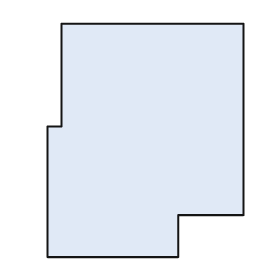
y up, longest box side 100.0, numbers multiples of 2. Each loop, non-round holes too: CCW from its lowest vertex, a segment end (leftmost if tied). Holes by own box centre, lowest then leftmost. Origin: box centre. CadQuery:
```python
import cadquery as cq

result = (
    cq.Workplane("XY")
    .moveTo(-42.0, -50.0)
    .lineTo(14.0, -50.0)
    .lineTo(14.0, -32.0)
    .lineTo(42.0, -32.0)
    .lineTo(42.0, 50.0)
    .lineTo(-36.0, 50.0)
    .lineTo(-36.0, 6.0)
    .lineTo(-42.0, 6.0)
    .close()
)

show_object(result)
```